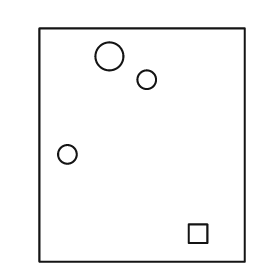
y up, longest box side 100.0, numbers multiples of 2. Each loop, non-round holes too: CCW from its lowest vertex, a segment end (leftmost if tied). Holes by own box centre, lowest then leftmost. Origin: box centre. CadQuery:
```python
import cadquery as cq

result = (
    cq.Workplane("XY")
    .moveTo(-44.0, -50.0)
    .lineTo(44.0, -50.0)
    .lineTo(44.0, 50.0)
    .lineTo(-44.0, 50.0)
    .close()
    .moveTo(20.0, -42.0)
    .lineTo(28.0, -42.0)
    .lineTo(28.0, -34.0)
    .lineTo(20.0, -34.0)
    .close()
    .moveTo(-32.0, -4.0)
    .circle(4.0)
    .moveTo(2.0, 28.0)
    .circle(4.0)
    .moveTo(-14.0, 38.0)
    .circle(6.0)
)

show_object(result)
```